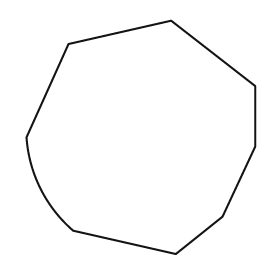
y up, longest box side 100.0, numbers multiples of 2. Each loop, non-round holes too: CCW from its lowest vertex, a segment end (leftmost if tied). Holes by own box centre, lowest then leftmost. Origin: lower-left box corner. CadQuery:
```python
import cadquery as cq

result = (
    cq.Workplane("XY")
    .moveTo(64.0, 0.0)
    .lineTo(84.0, 16.0)
    .lineTo(98.0, 46.0)
    .lineTo(98.0, 72.0)
    .lineTo(62.0, 100.0)
    .lineTo(18.0, 90.0)
    .lineTo(0.0, 50.0)
    .threePointArc((6.0, 28.0), (20.0, 10.0))
    .close()
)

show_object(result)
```